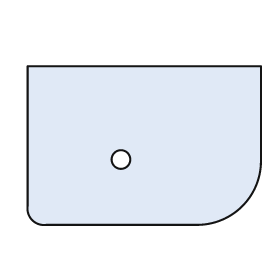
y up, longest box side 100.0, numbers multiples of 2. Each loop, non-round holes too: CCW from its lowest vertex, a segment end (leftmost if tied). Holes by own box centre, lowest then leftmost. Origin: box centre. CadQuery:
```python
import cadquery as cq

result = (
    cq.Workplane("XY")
    .moveTo(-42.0, -34.0)
    .lineTo(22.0, -34.0)
    .threePointArc((42.0, -26.0), (50.0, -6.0))
    .lineTo(50.0, 34.0)
    .lineTo(-50.0, 34.0)
    .lineTo(-50.0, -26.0)
    .threePointArc((-48.0, -32.0), (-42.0, -34.0))
    .close()
    .moveTo(-10.0, -6.0)
    .circle(4.0)
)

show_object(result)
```